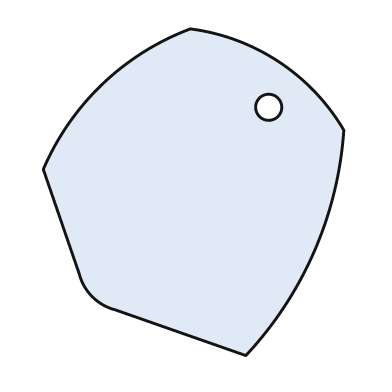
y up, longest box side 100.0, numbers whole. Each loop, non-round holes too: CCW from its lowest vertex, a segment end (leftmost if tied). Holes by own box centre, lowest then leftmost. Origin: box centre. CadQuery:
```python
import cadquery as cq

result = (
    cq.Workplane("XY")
    .moveTo(16.0, -50.0)
    .threePointArc((37.0, -18.0), (46.0, 19.0))
    .threePointArc((26.0, 40.0), (-1.0, 50.0))
    .threePointArc((-28.0, 33.0), (-46.0, 7.0))
    .lineTo(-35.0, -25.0)
    .threePointArc((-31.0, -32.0), (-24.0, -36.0))
    .close()
    .moveTo(23.0, 26.0)
    .circle(4.0)
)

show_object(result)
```